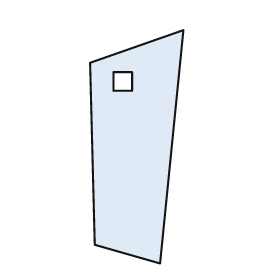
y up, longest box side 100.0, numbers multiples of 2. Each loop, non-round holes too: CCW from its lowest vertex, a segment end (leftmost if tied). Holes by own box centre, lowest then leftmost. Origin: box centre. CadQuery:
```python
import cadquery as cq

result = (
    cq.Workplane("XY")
    .moveTo(10.0, -50.0)
    .lineTo(20.0, 50.0)
    .lineTo(-20.0, 36.0)
    .lineTo(-18.0, -42.0)
    .close()
    .moveTo(-10.0, 24.0)
    .lineTo(-2.0, 24.0)
    .lineTo(-2.0, 32.0)
    .lineTo(-10.0, 32.0)
    .close()
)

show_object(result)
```